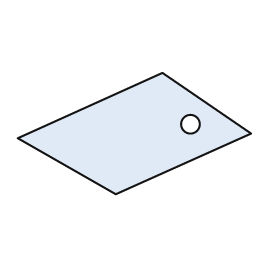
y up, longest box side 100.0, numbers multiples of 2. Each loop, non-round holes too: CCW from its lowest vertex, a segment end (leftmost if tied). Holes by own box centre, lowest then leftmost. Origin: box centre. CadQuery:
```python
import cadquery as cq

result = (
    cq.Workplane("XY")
    .moveTo(-8.0, -26.0)
    .lineTo(50.0, 0.0)
    .lineTo(12.0, 26.0)
    .lineTo(-50.0, -2.0)
    .close()
    .moveTo(24.0, 4.0)
    .circle(4.0)
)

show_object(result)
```